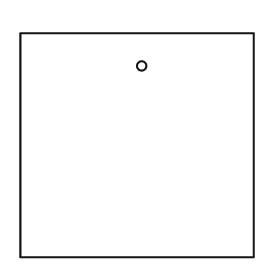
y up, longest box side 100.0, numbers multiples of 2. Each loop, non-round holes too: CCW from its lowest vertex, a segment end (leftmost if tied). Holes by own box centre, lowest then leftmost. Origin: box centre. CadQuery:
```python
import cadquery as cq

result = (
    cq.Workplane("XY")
    .moveTo(-50.0, -48.0)
    .lineTo(50.0, -48.0)
    .lineTo(50.0, 48.0)
    .lineTo(-50.0, 48.0)
    .close()
    .moveTo(2.0, 34.0)
    .circle(2.0)
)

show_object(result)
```